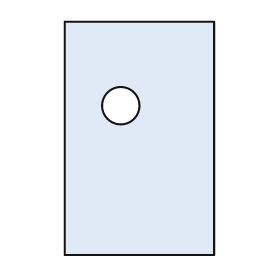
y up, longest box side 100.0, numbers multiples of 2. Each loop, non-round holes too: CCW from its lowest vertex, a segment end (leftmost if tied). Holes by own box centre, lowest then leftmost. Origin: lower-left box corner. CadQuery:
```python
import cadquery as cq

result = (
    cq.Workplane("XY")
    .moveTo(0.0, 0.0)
    .lineTo(64.0, 0.0)
    .lineTo(64.0, 100.0)
    .lineTo(0.0, 100.0)
    .close()
    .moveTo(24.0, 64.0)
    .circle(8.0)
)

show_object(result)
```